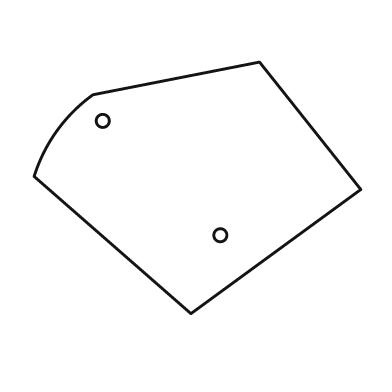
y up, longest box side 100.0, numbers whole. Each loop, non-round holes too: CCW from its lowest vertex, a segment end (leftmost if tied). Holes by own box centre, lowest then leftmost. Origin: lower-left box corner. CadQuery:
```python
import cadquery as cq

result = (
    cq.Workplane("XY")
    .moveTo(48.0, 0.0)
    .lineTo(100.0, 38.0)
    .lineTo(69.0, 77.0)
    .lineTo(18.0, 67.0)
    .threePointArc((7.0, 56.0), (0.0, 42.0))
    .close()
    .moveTo(57.0, 24.0)
    .circle(2.0)
    .moveTo(21.0, 59.0)
    .circle(2.0)
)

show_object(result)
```